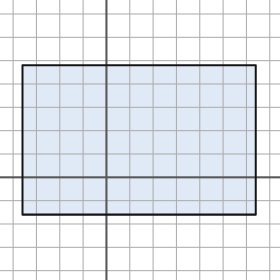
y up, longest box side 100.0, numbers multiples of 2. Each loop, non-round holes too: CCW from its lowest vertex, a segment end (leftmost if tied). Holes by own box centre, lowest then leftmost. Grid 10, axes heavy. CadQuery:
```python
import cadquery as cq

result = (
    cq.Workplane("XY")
    .moveTo(-36.0, -16.0)
    .lineTo(64.0, -16.0)
    .lineTo(64.0, 48.0)
    .lineTo(-36.0, 48.0)
    .close()
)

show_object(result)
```